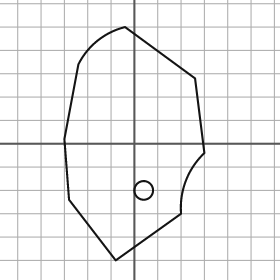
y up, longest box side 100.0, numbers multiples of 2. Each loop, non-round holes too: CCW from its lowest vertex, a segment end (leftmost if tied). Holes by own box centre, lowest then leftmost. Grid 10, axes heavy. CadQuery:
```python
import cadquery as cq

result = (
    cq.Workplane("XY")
    .moveTo(-8.0, -50.0)
    .lineTo(20.0, -30.0)
    .threePointArc((22.0, -16.0), (30.0, -4.0))
    .lineTo(26.0, 28.0)
    .lineTo(-4.0, 50.0)
    .threePointArc((-16.0, 44.0), (-24.0, 34.0))
    .lineTo(-30.0, 2.0)
    .lineTo(-28.0, -24.0)
    .close()
    .moveTo(4.0, -20.0)
    .circle(4.0)
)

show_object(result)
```